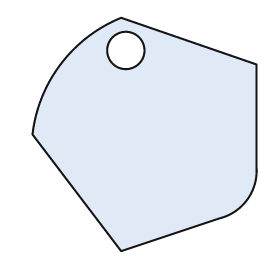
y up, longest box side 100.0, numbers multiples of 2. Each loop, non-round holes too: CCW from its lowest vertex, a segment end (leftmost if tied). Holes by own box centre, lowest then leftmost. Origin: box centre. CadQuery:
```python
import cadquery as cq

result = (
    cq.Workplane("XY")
    .moveTo(-10.0, -50.0)
    .lineTo(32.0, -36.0)
    .threePointArc((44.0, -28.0), (48.0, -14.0))
    .lineTo(48.0, 30.0)
    .lineTo(-10.0, 50.0)
    .threePointArc((-36.0, 30.0), (-48.0, 0.0))
    .close()
    .moveTo(-8.0, 36.0)
    .circle(8.0)
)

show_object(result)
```